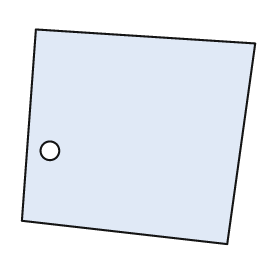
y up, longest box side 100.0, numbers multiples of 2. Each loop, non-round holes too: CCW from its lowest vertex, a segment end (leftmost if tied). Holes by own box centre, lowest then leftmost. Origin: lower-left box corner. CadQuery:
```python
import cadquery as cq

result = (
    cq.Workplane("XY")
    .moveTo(88.0, 0.0)
    .lineTo(100.0, 86.0)
    .lineTo(6.0, 92.0)
    .lineTo(0.0, 10.0)
    .close()
    .moveTo(12.0, 40.0)
    .circle(4.0)
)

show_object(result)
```